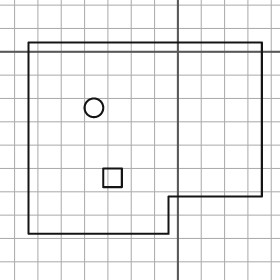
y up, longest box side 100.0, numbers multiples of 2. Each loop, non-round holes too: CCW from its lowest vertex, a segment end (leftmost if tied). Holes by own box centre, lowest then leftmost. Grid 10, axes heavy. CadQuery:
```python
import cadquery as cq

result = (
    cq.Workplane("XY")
    .moveTo(-64.0, -78.0)
    .lineTo(-4.0, -78.0)
    .lineTo(-4.0, -62.0)
    .lineTo(36.0, -62.0)
    .lineTo(36.0, 4.0)
    .lineTo(-64.0, 4.0)
    .close()
    .moveTo(-32.0, -58.0)
    .lineTo(-24.0, -58.0)
    .lineTo(-24.0, -50.0)
    .lineTo(-32.0, -50.0)
    .close()
    .moveTo(-36.0, -24.0)
    .circle(4.0)
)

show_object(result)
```